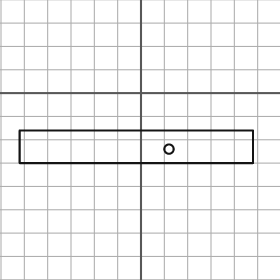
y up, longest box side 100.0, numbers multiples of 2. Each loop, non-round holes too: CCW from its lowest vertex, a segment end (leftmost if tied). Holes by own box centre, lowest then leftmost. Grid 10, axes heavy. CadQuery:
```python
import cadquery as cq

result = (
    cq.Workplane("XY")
    .moveTo(-52.0, -30.0)
    .lineTo(48.0, -30.0)
    .lineTo(48.0, -16.0)
    .lineTo(-52.0, -16.0)
    .close()
    .moveTo(12.0, -24.0)
    .circle(2.0)
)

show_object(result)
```